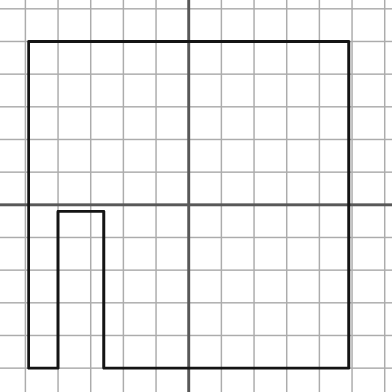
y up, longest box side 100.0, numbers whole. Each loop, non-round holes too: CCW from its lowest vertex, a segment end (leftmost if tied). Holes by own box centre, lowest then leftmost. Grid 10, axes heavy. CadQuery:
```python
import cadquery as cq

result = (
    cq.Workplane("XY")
    .moveTo(-49.0, -50.0)
    .lineTo(-40.0, -50.0)
    .lineTo(-40.0, -2.0)
    .lineTo(-26.0, -2.0)
    .lineTo(-26.0, -50.0)
    .lineTo(49.0, -50.0)
    .lineTo(49.0, 50.0)
    .lineTo(-49.0, 50.0)
    .close()
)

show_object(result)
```